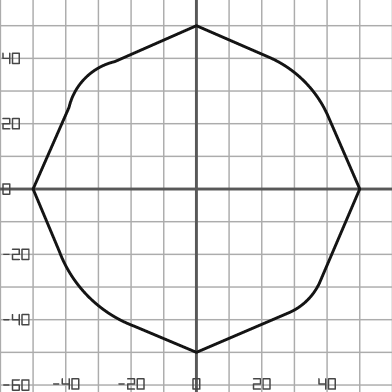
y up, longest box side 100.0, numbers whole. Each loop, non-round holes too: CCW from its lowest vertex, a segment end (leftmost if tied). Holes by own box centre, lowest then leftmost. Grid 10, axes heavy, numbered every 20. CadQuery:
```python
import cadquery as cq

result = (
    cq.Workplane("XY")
    .moveTo(0.0, -50.0)
    .lineTo(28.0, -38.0)
    .threePointArc((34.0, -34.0), (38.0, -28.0))
    .lineTo(50.0, 0.0)
    .lineTo(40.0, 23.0)
    .threePointArc((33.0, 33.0), (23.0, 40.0))
    .lineTo(0.0, 50.0)
    .lineTo(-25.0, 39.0)
    .threePointArc((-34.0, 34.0), (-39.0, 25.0))
    .lineTo(-50.0, 0.0)
    .lineTo(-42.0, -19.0)
    .threePointArc((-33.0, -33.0), (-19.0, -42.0))
    .close()
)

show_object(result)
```